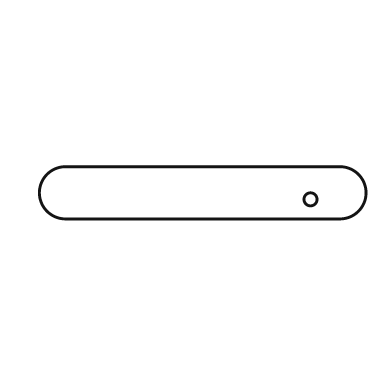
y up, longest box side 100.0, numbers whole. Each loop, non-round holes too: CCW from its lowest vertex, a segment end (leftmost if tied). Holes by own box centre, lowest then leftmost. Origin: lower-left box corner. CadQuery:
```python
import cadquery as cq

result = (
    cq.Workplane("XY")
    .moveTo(8.0, 0.0)
    .lineTo(92.0, 0.0)
    .threePointArc((100.0, 8.0), (92.0, 16.0))
    .lineTo(8.0, 16.0)
    .threePointArc((0.0, 8.0), (8.0, 0.0))
    .close()
    .moveTo(83.0, 6.0)
    .circle(2.0)
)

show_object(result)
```